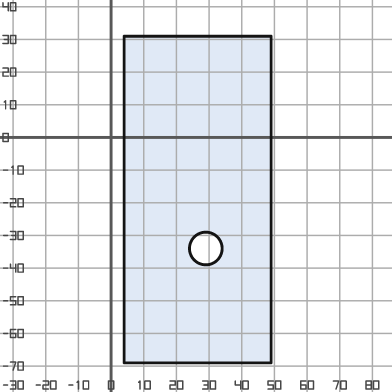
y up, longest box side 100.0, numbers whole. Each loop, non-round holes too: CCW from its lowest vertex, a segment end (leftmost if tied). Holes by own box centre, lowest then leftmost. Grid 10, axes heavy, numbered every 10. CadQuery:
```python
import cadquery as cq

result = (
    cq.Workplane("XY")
    .moveTo(4.0, -69.0)
    .lineTo(49.0, -69.0)
    .lineTo(49.0, 31.0)
    .lineTo(4.0, 31.0)
    .close()
    .moveTo(29.0, -34.0)
    .circle(5.0)
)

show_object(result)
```